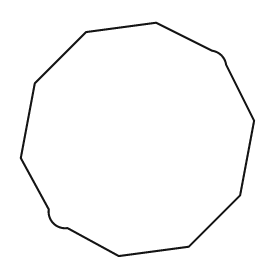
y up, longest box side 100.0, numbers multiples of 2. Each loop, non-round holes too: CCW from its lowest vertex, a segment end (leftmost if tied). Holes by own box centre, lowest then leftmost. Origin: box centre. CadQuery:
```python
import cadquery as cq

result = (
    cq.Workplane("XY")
    .moveTo(-8.0, -50.0)
    .lineTo(22.0, -46.0)
    .lineTo(44.0, -24.0)
    .lineTo(50.0, 8.0)
    .lineTo(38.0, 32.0)
    .threePointArc((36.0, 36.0), (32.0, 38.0))
    .lineTo(8.0, 50.0)
    .lineTo(-22.0, 46.0)
    .lineTo(-44.0, 24.0)
    .lineTo(-50.0, -8.0)
    .lineTo(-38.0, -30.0)
    .threePointArc((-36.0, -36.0), (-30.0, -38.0))
    .close()
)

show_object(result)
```